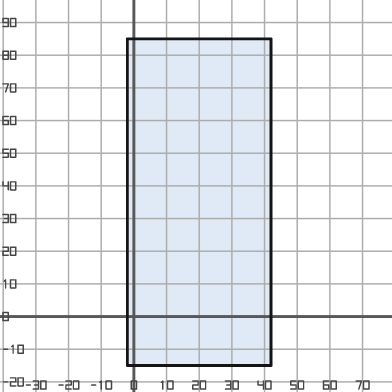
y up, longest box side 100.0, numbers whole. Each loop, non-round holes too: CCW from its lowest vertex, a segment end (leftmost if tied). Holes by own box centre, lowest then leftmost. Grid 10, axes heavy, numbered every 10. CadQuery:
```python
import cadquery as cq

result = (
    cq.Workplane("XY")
    .moveTo(-2.0, -15.0)
    .lineTo(42.0, -15.0)
    .lineTo(42.0, 85.0)
    .lineTo(-2.0, 85.0)
    .close()
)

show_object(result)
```